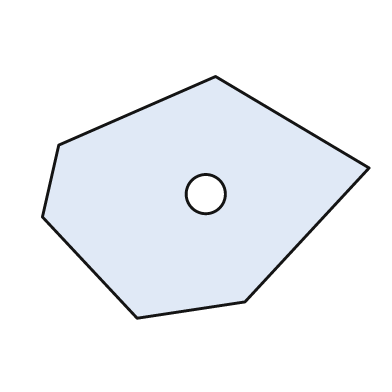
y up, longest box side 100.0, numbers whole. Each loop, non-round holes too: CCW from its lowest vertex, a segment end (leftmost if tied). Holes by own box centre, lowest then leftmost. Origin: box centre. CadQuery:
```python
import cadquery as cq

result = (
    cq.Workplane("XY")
    .moveTo(-21.0, -37.0)
    .lineTo(12.0, -32.0)
    .lineTo(50.0, 9.0)
    .lineTo(3.0, 37.0)
    .lineTo(-45.0, 16.0)
    .lineTo(-50.0, -6.0)
    .close()
    .moveTo(0.0, 1.0)
    .circle(6.0)
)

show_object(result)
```